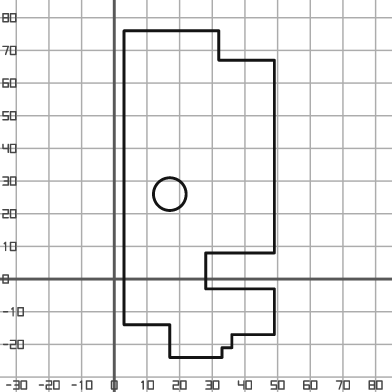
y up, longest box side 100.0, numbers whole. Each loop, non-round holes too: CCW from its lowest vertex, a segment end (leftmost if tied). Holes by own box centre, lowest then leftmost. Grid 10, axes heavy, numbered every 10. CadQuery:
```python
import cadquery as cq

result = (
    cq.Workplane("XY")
    .moveTo(17.0, -24.0)
    .lineTo(33.0, -24.0)
    .lineTo(33.0, -21.0)
    .lineTo(36.0, -21.0)
    .lineTo(36.0, -17.0)
    .lineTo(49.0, -17.0)
    .lineTo(49.0, -3.0)
    .lineTo(28.0, -3.0)
    .lineTo(28.0, 8.0)
    .lineTo(49.0, 8.0)
    .lineTo(49.0, 67.0)
    .lineTo(32.0, 67.0)
    .lineTo(32.0, 76.0)
    .lineTo(3.0, 76.0)
    .lineTo(3.0, -14.0)
    .lineTo(17.0, -14.0)
    .close()
    .moveTo(17.0, 26.0)
    .circle(5.0)
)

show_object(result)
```